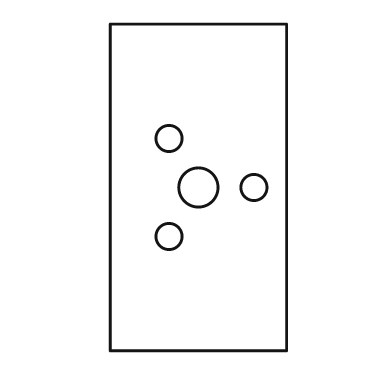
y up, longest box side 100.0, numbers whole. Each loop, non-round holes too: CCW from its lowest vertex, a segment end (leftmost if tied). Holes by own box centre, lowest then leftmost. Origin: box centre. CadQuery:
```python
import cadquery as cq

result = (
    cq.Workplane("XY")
    .moveTo(-27.0, -50.0)
    .lineTo(27.0, -50.0)
    .lineTo(27.0, 50.0)
    .lineTo(-27.0, 50.0)
    .close()
    .moveTo(-9.0, -15.0)
    .circle(4.0)
    .moveTo(0.0, 0.0)
    .circle(6.0)
    .moveTo(17.0, 0.0)
    .circle(4.0)
    .moveTo(-9.0, 15.0)
    .circle(4.0)
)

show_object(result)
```